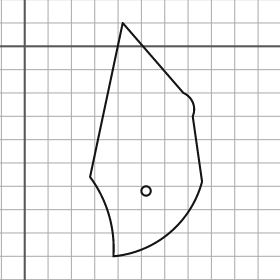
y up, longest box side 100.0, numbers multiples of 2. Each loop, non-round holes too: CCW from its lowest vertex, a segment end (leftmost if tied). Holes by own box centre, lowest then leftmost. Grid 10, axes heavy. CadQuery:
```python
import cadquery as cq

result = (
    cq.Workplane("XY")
    .moveTo(38.0, -90.0)
    .threePointArc((62.0, -80.0), (76.0, -58.0))
    .lineTo(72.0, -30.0)
    .threePointArc((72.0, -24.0), (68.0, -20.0))
    .lineTo(42.0, 10.0)
    .lineTo(28.0, -56.0)
    .threePointArc((36.0, -72.0), (38.0, -90.0))
    .close()
    .moveTo(52.0, -62.0)
    .circle(2.0)
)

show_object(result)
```